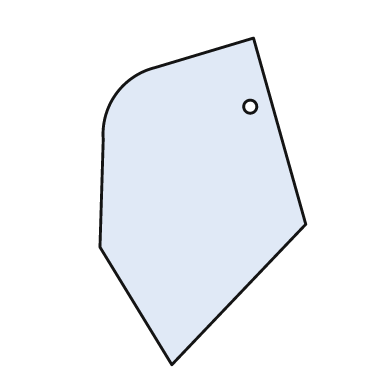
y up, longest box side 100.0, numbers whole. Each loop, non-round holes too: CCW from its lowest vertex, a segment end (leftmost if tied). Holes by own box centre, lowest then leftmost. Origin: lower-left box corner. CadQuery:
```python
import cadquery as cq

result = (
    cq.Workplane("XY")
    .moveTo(22.0, 0.0)
    .lineTo(63.0, 43.0)
    .lineTo(47.0, 100.0)
    .lineTo(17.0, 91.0)
    .threePointArc((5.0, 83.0), (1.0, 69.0))
    .lineTo(0.0, 36.0)
    .close()
    .moveTo(46.0, 79.0)
    .circle(2.0)
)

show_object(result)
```